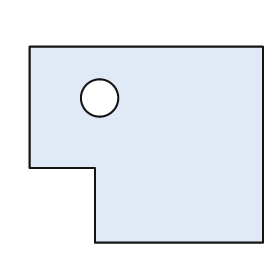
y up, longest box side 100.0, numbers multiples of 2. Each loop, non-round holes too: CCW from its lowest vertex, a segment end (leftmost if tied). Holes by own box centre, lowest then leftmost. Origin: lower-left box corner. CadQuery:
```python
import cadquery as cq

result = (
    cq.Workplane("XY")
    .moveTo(28.0, 0.0)
    .lineTo(100.0, 0.0)
    .lineTo(100.0, 84.0)
    .lineTo(0.0, 84.0)
    .lineTo(0.0, 32.0)
    .lineTo(28.0, 32.0)
    .close()
    .moveTo(30.0, 62.0)
    .circle(8.0)
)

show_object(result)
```